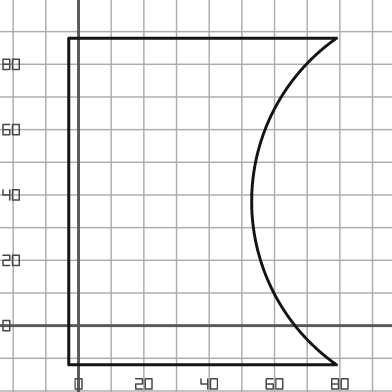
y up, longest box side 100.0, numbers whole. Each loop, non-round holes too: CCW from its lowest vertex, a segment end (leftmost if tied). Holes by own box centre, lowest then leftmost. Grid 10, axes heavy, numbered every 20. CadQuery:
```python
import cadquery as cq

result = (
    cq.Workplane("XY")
    .moveTo(-3.0, -12.0)
    .lineTo(79.0, -12.0)
    .threePointArc((53.0, 38.0), (79.0, 88.0))
    .lineTo(-3.0, 88.0)
    .close()
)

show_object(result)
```